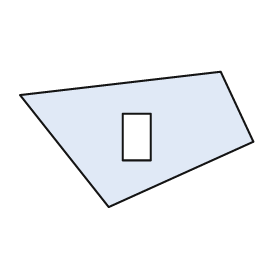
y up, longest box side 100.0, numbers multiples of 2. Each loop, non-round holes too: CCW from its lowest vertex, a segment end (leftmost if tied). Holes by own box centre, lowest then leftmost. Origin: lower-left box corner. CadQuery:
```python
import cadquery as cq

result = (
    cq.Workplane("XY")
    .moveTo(38.0, 0.0)
    .lineTo(100.0, 28.0)
    .lineTo(86.0, 58.0)
    .lineTo(0.0, 48.0)
    .close()
    .moveTo(44.0, 20.0)
    .lineTo(56.0, 20.0)
    .lineTo(56.0, 40.0)
    .lineTo(44.0, 40.0)
    .close()
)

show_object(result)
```